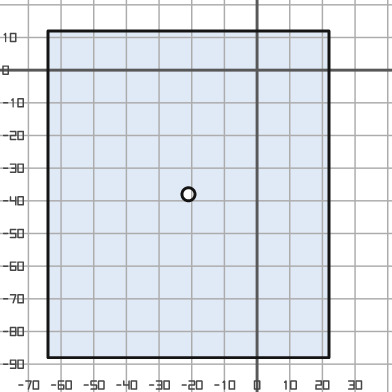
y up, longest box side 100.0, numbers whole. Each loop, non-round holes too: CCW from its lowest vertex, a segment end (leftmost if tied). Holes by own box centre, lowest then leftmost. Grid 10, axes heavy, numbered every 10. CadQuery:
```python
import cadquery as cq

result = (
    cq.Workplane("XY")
    .moveTo(-64.0, -88.0)
    .lineTo(22.0, -88.0)
    .lineTo(22.0, 12.0)
    .lineTo(-64.0, 12.0)
    .close()
    .moveTo(-21.0, -38.0)
    .circle(2.0)
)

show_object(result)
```